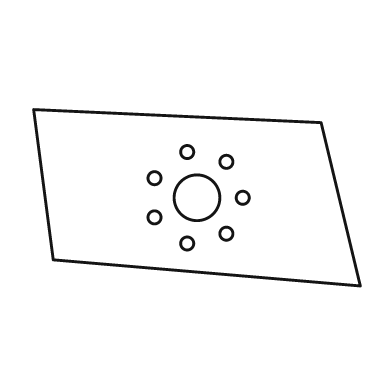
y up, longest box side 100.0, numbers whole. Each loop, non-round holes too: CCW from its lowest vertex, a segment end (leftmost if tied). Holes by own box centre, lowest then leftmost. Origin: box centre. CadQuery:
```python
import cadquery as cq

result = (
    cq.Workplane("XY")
    .moveTo(50.0, -27.0)
    .lineTo(38.0, 23.0)
    .lineTo(-50.0, 27.0)
    .lineTo(-44.0, -19.0)
    .close()
    .moveTo(-3.0, -14.0)
    .circle(2.0)
    .moveTo(9.0, -11.0)
    .circle(2.0)
    .moveTo(-13.0, -6.0)
    .circle(2.0)
    .moveTo(0.0, 0.0)
    .circle(7.0)
    .moveTo(14.0, 0.0)
    .circle(2.0)
    .moveTo(-13.0, 6.0)
    .circle(2.0)
    .moveTo(9.0, 11.0)
    .circle(2.0)
    .moveTo(-3.0, 14.0)
    .circle(2.0)
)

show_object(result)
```